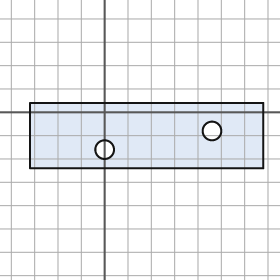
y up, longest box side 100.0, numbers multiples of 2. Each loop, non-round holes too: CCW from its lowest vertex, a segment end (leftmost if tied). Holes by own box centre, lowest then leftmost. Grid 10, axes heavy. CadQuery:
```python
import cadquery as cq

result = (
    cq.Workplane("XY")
    .moveTo(-32.0, -24.0)
    .lineTo(68.0, -24.0)
    .lineTo(68.0, 4.0)
    .lineTo(-32.0, 4.0)
    .close()
    .moveTo(0.0, -16.0)
    .circle(4.0)
    .moveTo(46.0, -8.0)
    .circle(4.0)
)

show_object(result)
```